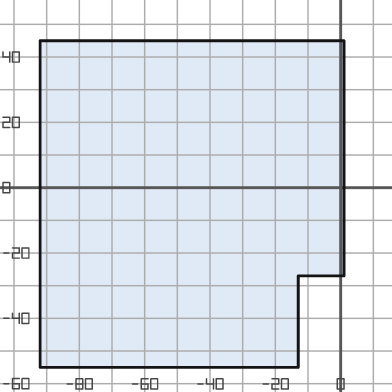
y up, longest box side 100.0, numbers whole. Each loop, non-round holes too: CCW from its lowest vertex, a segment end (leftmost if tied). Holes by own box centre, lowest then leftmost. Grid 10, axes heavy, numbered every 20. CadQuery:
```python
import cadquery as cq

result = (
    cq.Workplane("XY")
    .moveTo(-92.0, -55.0)
    .lineTo(-13.0, -55.0)
    .lineTo(-13.0, -27.0)
    .lineTo(1.0, -27.0)
    .lineTo(1.0, 45.0)
    .lineTo(-92.0, 45.0)
    .close()
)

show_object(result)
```